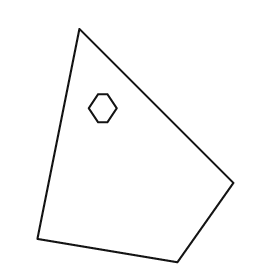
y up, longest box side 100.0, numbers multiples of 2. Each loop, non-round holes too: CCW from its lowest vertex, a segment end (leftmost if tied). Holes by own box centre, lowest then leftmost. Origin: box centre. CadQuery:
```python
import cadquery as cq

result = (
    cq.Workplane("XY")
    .moveTo(18.0, -50.0)
    .lineTo(42.0, -16.0)
    .lineTo(-24.0, 50.0)
    .lineTo(-42.0, -40.0)
    .close()
    .moveTo(-16.0, 10.0)
    .lineTo(-12.0, 10.0)
    .lineTo(-8.0, 16.0)
    .lineTo(-12.0, 22.0)
    .lineTo(-16.0, 22.0)
    .lineTo(-20.0, 16.0)
    .close()
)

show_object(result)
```